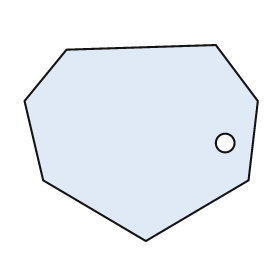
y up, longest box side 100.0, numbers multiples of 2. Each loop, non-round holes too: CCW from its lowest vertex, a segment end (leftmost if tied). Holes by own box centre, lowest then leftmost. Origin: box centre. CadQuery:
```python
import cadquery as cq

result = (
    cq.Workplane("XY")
    .moveTo(2.0, -42.0)
    .lineTo(46.0, -16.0)
    .lineTo(50.0, 18.0)
    .lineTo(32.0, 42.0)
    .lineTo(-32.0, 40.0)
    .lineTo(-50.0, 18.0)
    .lineTo(-42.0, -16.0)
    .close()
    .moveTo(36.0, 0.0)
    .circle(4.0)
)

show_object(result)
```